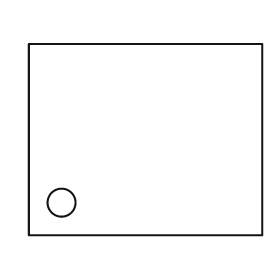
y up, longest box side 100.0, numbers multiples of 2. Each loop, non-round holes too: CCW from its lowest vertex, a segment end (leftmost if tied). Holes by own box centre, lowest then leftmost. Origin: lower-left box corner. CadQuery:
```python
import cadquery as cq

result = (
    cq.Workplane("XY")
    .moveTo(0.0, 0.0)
    .lineTo(100.0, 0.0)
    .lineTo(100.0, 82.0)
    .lineTo(0.0, 82.0)
    .close()
    .moveTo(14.0, 14.0)
    .circle(6.0)
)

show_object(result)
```